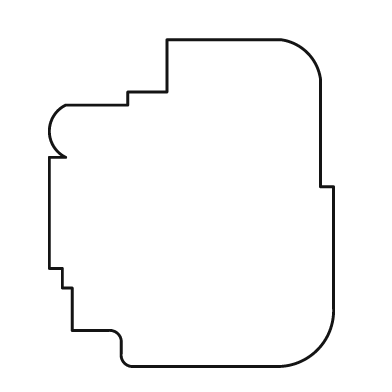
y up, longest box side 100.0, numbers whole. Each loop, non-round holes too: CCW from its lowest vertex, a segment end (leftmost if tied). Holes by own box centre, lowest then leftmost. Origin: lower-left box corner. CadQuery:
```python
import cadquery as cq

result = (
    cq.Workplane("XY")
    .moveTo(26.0, 0.0)
    .lineTo(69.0, 0.0)
    .threePointArc((82.0, 5.0), (87.0, 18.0))
    .lineTo(87.0, 55.0)
    .lineTo(83.0, 55.0)
    .lineTo(83.0, 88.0)
    .threePointArc((79.0, 96.0), (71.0, 100.0))
    .lineTo(36.0, 100.0)
    .lineTo(36.0, 84.0)
    .lineTo(24.0, 84.0)
    .lineTo(24.0, 80.0)
    .lineTo(5.0, 80.0)
    .threePointArc((0.0, 72.0), (5.0, 64.0))
    .lineTo(0.0, 64.0)
    .lineTo(0.0, 30.0)
    .lineTo(4.0, 30.0)
    .lineTo(4.0, 24.0)
    .lineTo(7.0, 24.0)
    .lineTo(7.0, 11.0)
    .lineTo(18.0, 11.0)
    .threePointArc((21.0, 10.0), (22.0, 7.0))
    .lineTo(22.0, 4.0)
    .threePointArc((23.0, 1.0), (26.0, 0.0))
    .close()
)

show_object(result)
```